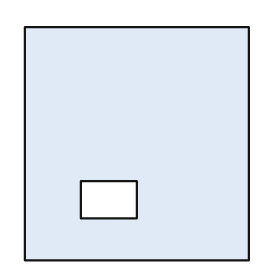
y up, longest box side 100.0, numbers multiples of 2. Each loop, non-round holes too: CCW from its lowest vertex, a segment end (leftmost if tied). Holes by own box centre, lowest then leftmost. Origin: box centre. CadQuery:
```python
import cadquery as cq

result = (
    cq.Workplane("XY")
    .moveTo(-48.0, -50.0)
    .lineTo(48.0, -50.0)
    .lineTo(48.0, 50.0)
    .lineTo(-48.0, 50.0)
    .close()
    .moveTo(-24.0, -32.0)
    .lineTo(0.0, -32.0)
    .lineTo(0.0, -16.0)
    .lineTo(-24.0, -16.0)
    .close()
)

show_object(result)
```